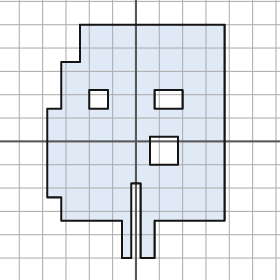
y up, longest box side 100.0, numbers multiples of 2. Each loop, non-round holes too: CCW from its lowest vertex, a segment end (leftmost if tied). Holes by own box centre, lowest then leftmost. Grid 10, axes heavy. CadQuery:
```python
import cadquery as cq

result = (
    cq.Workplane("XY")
    .moveTo(-6.0, -50.0)
    .lineTo(-2.0, -50.0)
    .lineTo(-2.0, -18.0)
    .lineTo(2.0, -18.0)
    .lineTo(2.0, -50.0)
    .lineTo(8.0, -50.0)
    .lineTo(8.0, -34.0)
    .lineTo(38.0, -34.0)
    .lineTo(38.0, 50.0)
    .lineTo(-24.0, 50.0)
    .lineTo(-24.0, 34.0)
    .lineTo(-32.0, 34.0)
    .lineTo(-32.0, 14.0)
    .lineTo(-38.0, 14.0)
    .lineTo(-38.0, -24.0)
    .lineTo(-32.0, -24.0)
    .lineTo(-32.0, -34.0)
    .lineTo(-6.0, -34.0)
    .close()
    .moveTo(6.0, -10.0)
    .lineTo(18.0, -10.0)
    .lineTo(18.0, 2.0)
    .lineTo(6.0, 2.0)
    .close()
    .moveTo(-20.0, 14.0)
    .lineTo(-12.0, 14.0)
    .lineTo(-12.0, 22.0)
    .lineTo(-20.0, 22.0)
    .close()
    .moveTo(8.0, 14.0)
    .lineTo(20.0, 14.0)
    .lineTo(20.0, 22.0)
    .lineTo(8.0, 22.0)
    .close()
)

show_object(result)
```